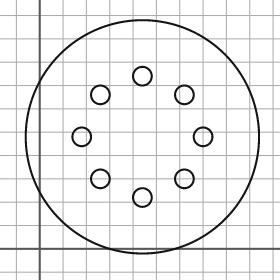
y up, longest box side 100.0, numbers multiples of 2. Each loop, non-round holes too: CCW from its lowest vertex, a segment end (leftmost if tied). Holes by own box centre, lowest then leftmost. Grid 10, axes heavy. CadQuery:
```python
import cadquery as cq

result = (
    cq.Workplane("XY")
    .moveTo(44.0, 48.0)
    .circle(50.0)
    .moveTo(44.0, 22.0)
    .circle(4.0)
    .moveTo(26.0, 30.0)
    .circle(4.0)
    .moveTo(62.0, 30.0)
    .circle(4.0)
    .moveTo(18.0, 48.0)
    .circle(4.0)
    .moveTo(70.0, 48.0)
    .circle(4.0)
    .moveTo(26.0, 66.0)
    .circle(4.0)
    .moveTo(62.0, 66.0)
    .circle(4.0)
    .moveTo(44.0, 74.0)
    .circle(4.0)
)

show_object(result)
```